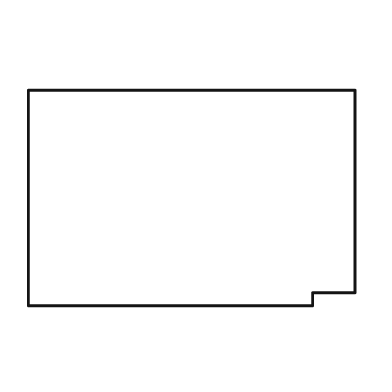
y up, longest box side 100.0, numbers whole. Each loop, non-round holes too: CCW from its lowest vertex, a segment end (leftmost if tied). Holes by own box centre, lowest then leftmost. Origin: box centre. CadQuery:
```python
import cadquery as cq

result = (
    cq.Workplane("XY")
    .moveTo(-50.0, -33.0)
    .lineTo(37.0, -33.0)
    .lineTo(37.0, -29.0)
    .lineTo(50.0, -29.0)
    .lineTo(50.0, 33.0)
    .lineTo(-50.0, 33.0)
    .close()
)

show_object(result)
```